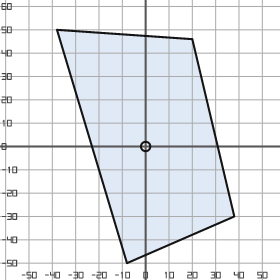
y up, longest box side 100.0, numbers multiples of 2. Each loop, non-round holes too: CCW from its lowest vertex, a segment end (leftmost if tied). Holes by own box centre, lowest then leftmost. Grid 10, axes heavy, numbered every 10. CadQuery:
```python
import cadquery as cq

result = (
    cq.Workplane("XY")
    .moveTo(-8.0, -50.0)
    .lineTo(38.0, -30.0)
    .lineTo(20.0, 46.0)
    .lineTo(-38.0, 50.0)
    .close()
    .moveTo(0.0, 0.0)
    .circle(2.0)
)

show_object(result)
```